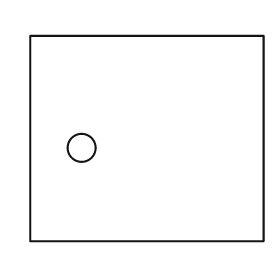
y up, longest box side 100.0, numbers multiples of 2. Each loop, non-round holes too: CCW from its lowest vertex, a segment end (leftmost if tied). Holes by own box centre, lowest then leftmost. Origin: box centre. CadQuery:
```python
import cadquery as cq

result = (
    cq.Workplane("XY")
    .moveTo(-50.0, -44.0)
    .lineTo(50.0, -44.0)
    .lineTo(50.0, 44.0)
    .lineTo(-50.0, 44.0)
    .close()
    .moveTo(-28.0, -4.0)
    .circle(6.0)
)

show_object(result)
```